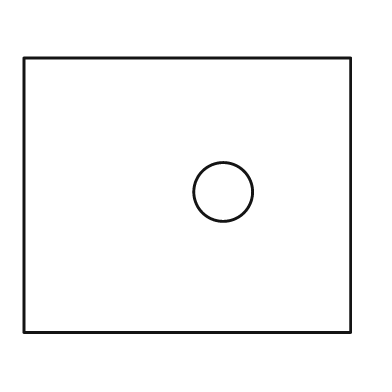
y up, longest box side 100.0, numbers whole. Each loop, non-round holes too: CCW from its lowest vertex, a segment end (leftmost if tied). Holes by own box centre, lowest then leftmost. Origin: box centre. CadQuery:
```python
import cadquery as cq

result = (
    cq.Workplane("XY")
    .moveTo(-50.0, -42.0)
    .lineTo(50.0, -42.0)
    .lineTo(50.0, 42.0)
    .lineTo(-50.0, 42.0)
    .close()
    .moveTo(11.0, 1.0)
    .circle(9.0)
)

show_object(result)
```